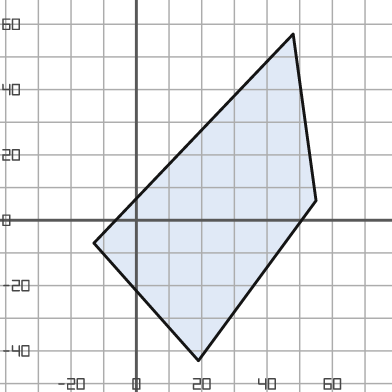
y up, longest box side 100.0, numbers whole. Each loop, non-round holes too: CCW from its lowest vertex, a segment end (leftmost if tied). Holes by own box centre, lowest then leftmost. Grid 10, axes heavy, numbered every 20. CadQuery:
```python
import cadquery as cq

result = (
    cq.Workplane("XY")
    .moveTo(19.0, -43.0)
    .lineTo(55.0, 6.0)
    .lineTo(48.0, 57.0)
    .lineTo(-13.0, -7.0)
    .close()
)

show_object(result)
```